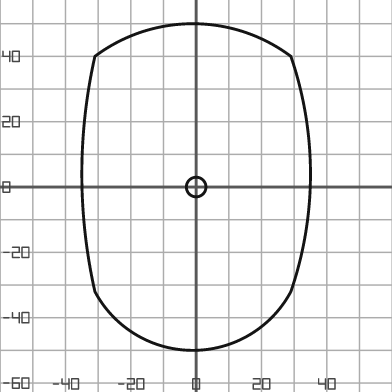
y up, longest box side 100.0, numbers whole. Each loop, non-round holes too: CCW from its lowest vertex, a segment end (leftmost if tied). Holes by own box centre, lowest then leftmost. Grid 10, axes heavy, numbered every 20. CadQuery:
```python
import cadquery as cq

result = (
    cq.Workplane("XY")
    .moveTo(-31.0, -32.0)
    .threePointArc((-1.0, -50.0), (29.0, -32.0))
    .threePointArc((35.0, 4.0), (29.0, 40.0))
    .threePointArc((-1.0, 50.0), (-31.0, 40.0))
    .threePointArc((-35.0, 4.0), (-31.0, -32.0))
    .close()
    .moveTo(0.0, 0.0)
    .circle(3.0)
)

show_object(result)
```